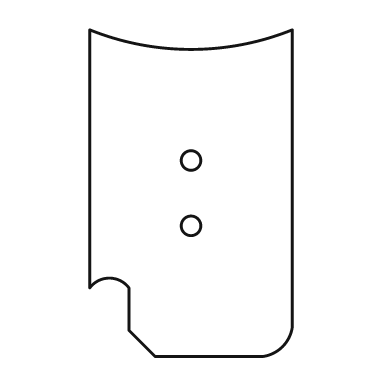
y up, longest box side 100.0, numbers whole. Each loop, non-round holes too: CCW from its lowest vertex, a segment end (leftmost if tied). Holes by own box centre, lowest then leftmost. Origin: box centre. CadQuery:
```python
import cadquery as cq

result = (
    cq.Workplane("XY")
    .moveTo(-11.0, -50.0)
    .lineTo(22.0, -50.0)
    .threePointArc((28.0, -47.0), (31.0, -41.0))
    .lineTo(31.0, 50.0)
    .threePointArc((0.0, 44.0), (-31.0, 50.0))
    .lineTo(-31.0, -29.0)
    .threePointArc((-25.0, -26.0), (-19.0, -29.0))
    .lineTo(-19.0, -42.0)
    .close()
    .moveTo(0.0, -10.0)
    .circle(3.0)
    .moveTo(0.0, 10.0)
    .circle(3.0)
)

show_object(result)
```